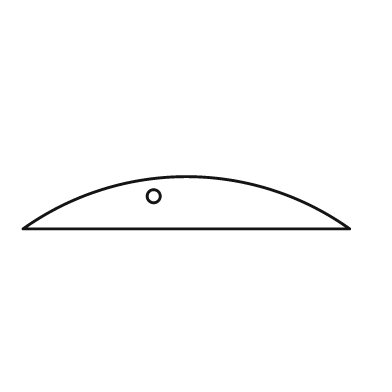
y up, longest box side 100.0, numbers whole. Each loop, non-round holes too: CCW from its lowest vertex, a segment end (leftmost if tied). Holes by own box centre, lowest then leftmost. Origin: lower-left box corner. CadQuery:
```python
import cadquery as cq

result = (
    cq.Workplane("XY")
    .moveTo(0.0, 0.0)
    .lineTo(100.0, 0.0)
    .threePointArc((50.0, 16.0), (0.0, 0.0))
    .close()
    .moveTo(40.0, 10.0)
    .circle(2.0)
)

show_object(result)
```